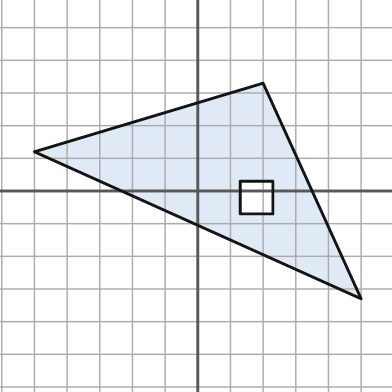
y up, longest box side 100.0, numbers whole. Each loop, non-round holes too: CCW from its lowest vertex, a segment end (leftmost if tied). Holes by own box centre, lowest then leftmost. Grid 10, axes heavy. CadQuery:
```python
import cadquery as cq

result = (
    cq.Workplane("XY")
    .moveTo(50.0, -33.0)
    .lineTo(20.0, 33.0)
    .lineTo(-50.0, 12.0)
    .close()
    .moveTo(13.0, -7.0)
    .lineTo(23.0, -7.0)
    .lineTo(23.0, 3.0)
    .lineTo(13.0, 3.0)
    .close()
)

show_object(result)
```